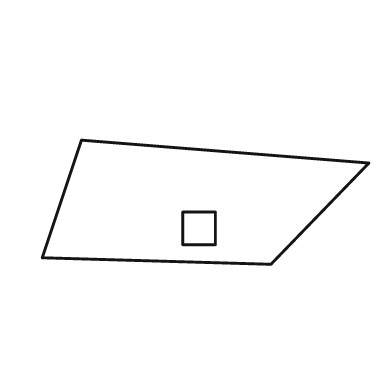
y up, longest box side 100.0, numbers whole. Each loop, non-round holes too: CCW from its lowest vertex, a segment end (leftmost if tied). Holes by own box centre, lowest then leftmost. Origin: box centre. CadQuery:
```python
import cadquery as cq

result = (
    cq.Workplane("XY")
    .moveTo(20.0, -19.0)
    .lineTo(50.0, 12.0)
    .lineTo(-38.0, 19.0)
    .lineTo(-50.0, -17.0)
    .close()
    .moveTo(-7.0, -13.0)
    .lineTo(3.0, -13.0)
    .lineTo(3.0, -3.0)
    .lineTo(-7.0, -3.0)
    .close()
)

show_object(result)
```